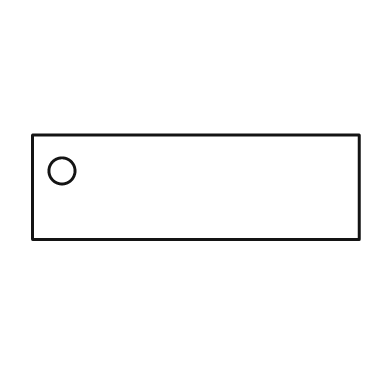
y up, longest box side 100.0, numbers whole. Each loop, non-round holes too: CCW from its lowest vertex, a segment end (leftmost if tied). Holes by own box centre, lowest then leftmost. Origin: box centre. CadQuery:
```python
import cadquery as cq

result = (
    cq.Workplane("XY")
    .moveTo(-50.0, -16.0)
    .lineTo(50.0, -16.0)
    .lineTo(50.0, 16.0)
    .lineTo(-50.0, 16.0)
    .close()
    .moveTo(-41.0, 5.0)
    .circle(4.0)
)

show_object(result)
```